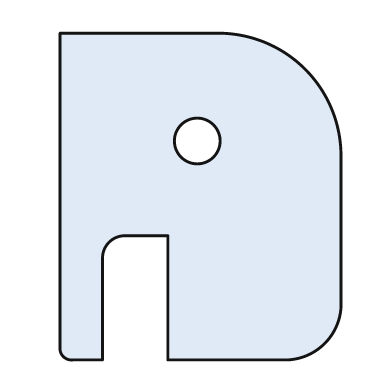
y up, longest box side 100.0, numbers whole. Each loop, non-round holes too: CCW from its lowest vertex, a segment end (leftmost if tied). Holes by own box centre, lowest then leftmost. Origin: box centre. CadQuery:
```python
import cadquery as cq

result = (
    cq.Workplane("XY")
    .moveTo(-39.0, -50.0)
    .lineTo(-30.0, -50.0)
    .lineTo(-30.0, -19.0)
    .threePointArc((-28.0, -14.0), (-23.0, -12.0))
    .lineTo(-10.0, -12.0)
    .lineTo(-10.0, -50.0)
    .lineTo(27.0, -50.0)
    .threePointArc((38.0, -45.0), (43.0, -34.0))
    .lineTo(43.0, 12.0)
    .threePointArc((32.0, 39.0), (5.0, 50.0))
    .lineTo(-43.0, 50.0)
    .lineTo(-43.0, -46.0)
    .threePointArc((-42.0, -49.0), (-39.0, -50.0))
    .close()
    .moveTo(-1.0, 17.0)
    .circle(7.0)
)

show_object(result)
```